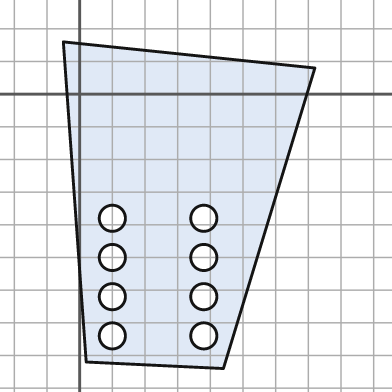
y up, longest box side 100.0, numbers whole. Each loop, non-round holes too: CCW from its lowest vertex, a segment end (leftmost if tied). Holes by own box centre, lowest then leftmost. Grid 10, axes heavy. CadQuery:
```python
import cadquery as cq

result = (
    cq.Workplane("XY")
    .moveTo(44.0, -84.0)
    .lineTo(72.0, 8.0)
    .lineTo(-5.0, 16.0)
    .lineTo(2.0, -82.0)
    .close()
    .moveTo(10.0, -74.0)
    .circle(4.0)
    .moveTo(38.0, -74.0)
    .circle(4.0)
    .moveTo(10.0, -62.0)
    .circle(4.0)
    .moveTo(38.0, -62.0)
    .circle(4.0)
    .moveTo(10.0, -50.0)
    .circle(4.0)
    .moveTo(38.0, -50.0)
    .circle(4.0)
    .moveTo(10.0, -38.0)
    .circle(4.0)
    .moveTo(38.0, -38.0)
    .circle(4.0)
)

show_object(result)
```